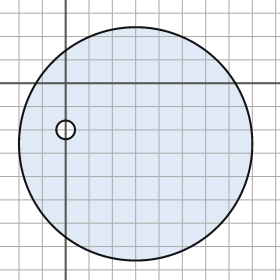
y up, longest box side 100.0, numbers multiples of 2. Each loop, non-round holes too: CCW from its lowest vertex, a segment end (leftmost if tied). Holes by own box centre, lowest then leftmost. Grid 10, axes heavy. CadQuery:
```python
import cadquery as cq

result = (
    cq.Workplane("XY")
    .moveTo(30.0, -26.0)
    .circle(50.0)
    .moveTo(0.0, -20.0)
    .circle(4.0)
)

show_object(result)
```